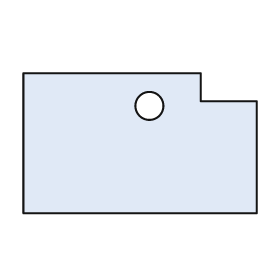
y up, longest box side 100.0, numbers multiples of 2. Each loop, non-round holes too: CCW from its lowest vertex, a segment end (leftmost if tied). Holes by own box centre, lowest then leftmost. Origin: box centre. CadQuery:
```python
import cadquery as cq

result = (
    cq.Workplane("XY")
    .moveTo(-50.0, -30.0)
    .lineTo(50.0, -30.0)
    .lineTo(50.0, 18.0)
    .lineTo(26.0, 18.0)
    .lineTo(26.0, 30.0)
    .lineTo(-50.0, 30.0)
    .close()
    .moveTo(4.0, 16.0)
    .circle(6.0)
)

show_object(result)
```